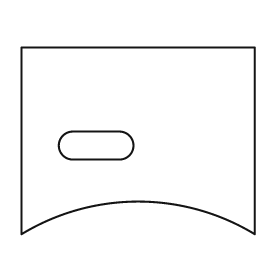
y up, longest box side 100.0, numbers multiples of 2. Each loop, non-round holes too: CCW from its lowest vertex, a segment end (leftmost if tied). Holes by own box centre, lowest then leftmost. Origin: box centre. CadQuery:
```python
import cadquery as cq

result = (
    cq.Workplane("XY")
    .moveTo(-50.0, -40.0)
    .threePointArc((0.0, -26.0), (50.0, -40.0))
    .lineTo(50.0, 40.0)
    .lineTo(-50.0, 40.0)
    .close()
    .moveTo(-28.0, -8.0)
    .lineTo(-8.0, -8.0)
    .threePointArc((-2.0, -2.0), (-8.0, 4.0))
    .lineTo(-28.0, 4.0)
    .threePointArc((-34.0, -2.0), (-28.0, -8.0))
    .close()
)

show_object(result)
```